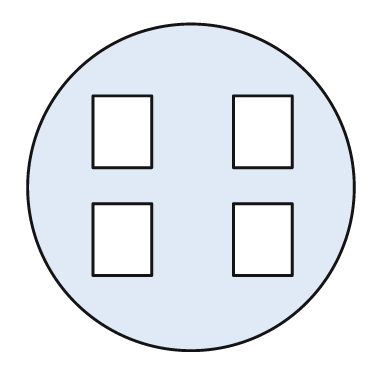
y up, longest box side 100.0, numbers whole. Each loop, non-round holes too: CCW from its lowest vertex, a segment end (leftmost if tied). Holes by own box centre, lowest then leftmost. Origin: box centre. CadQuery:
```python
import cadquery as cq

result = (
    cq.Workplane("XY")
    .moveTo(0.0, 0.0)
    .circle(50.0)
    .moveTo(-30.0, -27.0)
    .lineTo(-12.0, -27.0)
    .lineTo(-12.0, -5.0)
    .lineTo(-30.0, -5.0)
    .close()
    .moveTo(13.0, -27.0)
    .lineTo(31.0, -27.0)
    .lineTo(31.0, -5.0)
    .lineTo(13.0, -5.0)
    .close()
    .moveTo(-30.0, 6.0)
    .lineTo(-12.0, 6.0)
    .lineTo(-12.0, 28.0)
    .lineTo(-30.0, 28.0)
    .close()
    .moveTo(13.0, 6.0)
    .lineTo(31.0, 6.0)
    .lineTo(31.0, 28.0)
    .lineTo(13.0, 28.0)
    .close()
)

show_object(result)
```